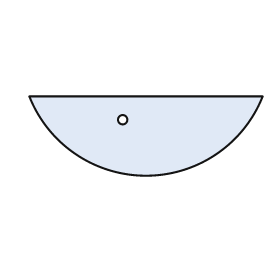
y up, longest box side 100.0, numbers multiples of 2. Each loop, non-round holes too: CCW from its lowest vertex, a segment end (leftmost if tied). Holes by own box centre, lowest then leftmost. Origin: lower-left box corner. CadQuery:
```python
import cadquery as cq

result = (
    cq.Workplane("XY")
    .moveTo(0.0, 34.0)
    .threePointArc((50.0, 0.0), (100.0, 34.0))
    .close()
    .moveTo(40.0, 24.0)
    .circle(2.0)
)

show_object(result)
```